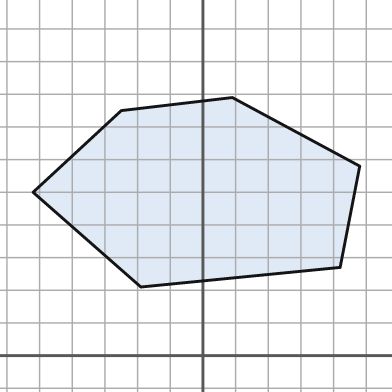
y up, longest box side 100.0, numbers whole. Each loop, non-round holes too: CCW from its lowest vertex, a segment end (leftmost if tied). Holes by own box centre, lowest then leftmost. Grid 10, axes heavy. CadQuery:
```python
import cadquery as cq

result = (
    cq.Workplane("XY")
    .moveTo(-19.0, 21.0)
    .lineTo(42.0, 27.0)
    .lineTo(48.0, 58.0)
    .lineTo(9.0, 79.0)
    .lineTo(-25.0, 75.0)
    .lineTo(-52.0, 50.0)
    .close()
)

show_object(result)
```